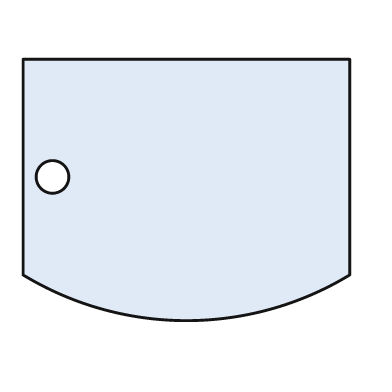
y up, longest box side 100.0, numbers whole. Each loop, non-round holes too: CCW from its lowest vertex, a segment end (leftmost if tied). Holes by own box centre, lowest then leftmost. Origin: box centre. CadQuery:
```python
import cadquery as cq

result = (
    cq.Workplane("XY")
    .moveTo(-50.0, -26.0)
    .threePointArc((0.0, -40.0), (50.0, -26.0))
    .lineTo(50.0, 40.0)
    .lineTo(-50.0, 40.0)
    .close()
    .moveTo(-41.0, 4.0)
    .circle(5.0)
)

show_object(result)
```